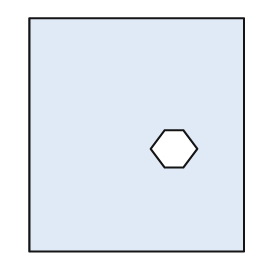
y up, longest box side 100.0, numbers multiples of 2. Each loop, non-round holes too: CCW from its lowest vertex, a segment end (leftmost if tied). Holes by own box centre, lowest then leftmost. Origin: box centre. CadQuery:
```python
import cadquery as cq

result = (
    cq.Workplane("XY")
    .moveTo(-46.0, -50.0)
    .lineTo(46.0, -50.0)
    .lineTo(46.0, 50.0)
    .lineTo(-46.0, 50.0)
    .close()
    .moveTo(12.0, -14.0)
    .lineTo(20.0, -14.0)
    .lineTo(26.0, -6.0)
    .lineTo(20.0, 2.0)
    .lineTo(12.0, 2.0)
    .lineTo(6.0, -6.0)
    .close()
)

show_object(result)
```